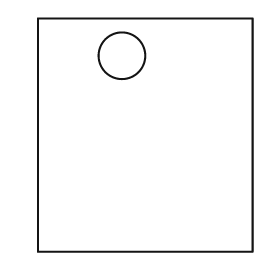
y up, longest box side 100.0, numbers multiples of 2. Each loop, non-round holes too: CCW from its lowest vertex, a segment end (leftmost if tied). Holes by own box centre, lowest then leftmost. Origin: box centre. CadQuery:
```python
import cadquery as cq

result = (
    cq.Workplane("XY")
    .moveTo(-46.0, -50.0)
    .lineTo(46.0, -50.0)
    .lineTo(46.0, 50.0)
    .lineTo(-46.0, 50.0)
    .close()
    .moveTo(-10.0, 34.0)
    .circle(10.0)
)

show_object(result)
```